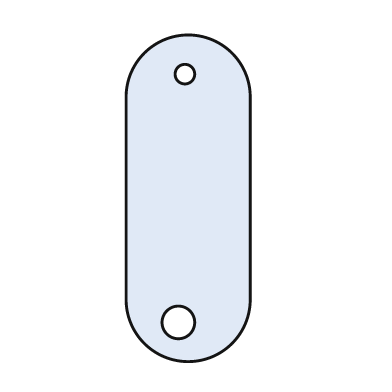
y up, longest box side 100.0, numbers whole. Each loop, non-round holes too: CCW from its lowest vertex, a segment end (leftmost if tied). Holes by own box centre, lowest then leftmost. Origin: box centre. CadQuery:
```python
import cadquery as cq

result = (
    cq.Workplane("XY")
    .moveTo(-19.0, -31.0)
    .threePointArc((0.0, -50.0), (19.0, -31.0))
    .lineTo(19.0, 31.0)
    .threePointArc((0.0, 50.0), (-19.0, 31.0))
    .close()
    .moveTo(-3.0, -38.0)
    .circle(5.0)
    .moveTo(-1.0, 38.0)
    .circle(3.0)
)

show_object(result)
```